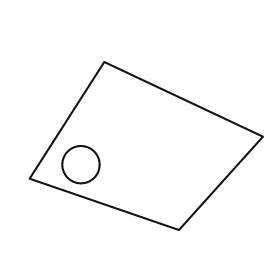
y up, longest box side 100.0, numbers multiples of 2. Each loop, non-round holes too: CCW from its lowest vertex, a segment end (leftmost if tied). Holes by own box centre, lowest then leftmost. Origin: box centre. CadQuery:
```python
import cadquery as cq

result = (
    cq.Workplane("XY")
    .moveTo(14.0, -36.0)
    .lineTo(50.0, 4.0)
    .lineTo(-18.0, 36.0)
    .lineTo(-50.0, -14.0)
    .close()
    .moveTo(-28.0, -8.0)
    .circle(8.0)
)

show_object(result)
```